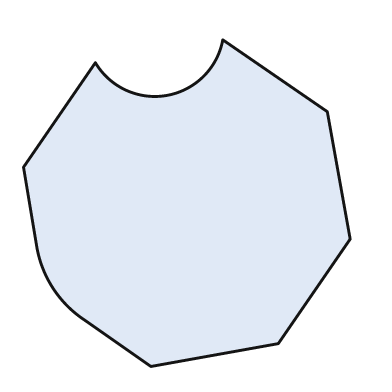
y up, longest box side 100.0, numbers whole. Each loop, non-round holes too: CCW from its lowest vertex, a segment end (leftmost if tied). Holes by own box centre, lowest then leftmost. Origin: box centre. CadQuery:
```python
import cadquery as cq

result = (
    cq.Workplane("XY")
    .moveTo(-11.0, -50.0)
    .lineTo(28.0, -43.0)
    .lineTo(50.0, -11.0)
    .lineTo(43.0, 28.0)
    .lineTo(11.0, 50.0)
    .threePointArc((-6.0, 33.0), (-28.0, 43.0))
    .lineTo(-50.0, 11.0)
    .lineTo(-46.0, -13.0)
    .threePointArc((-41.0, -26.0), (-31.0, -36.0))
    .close()
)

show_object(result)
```